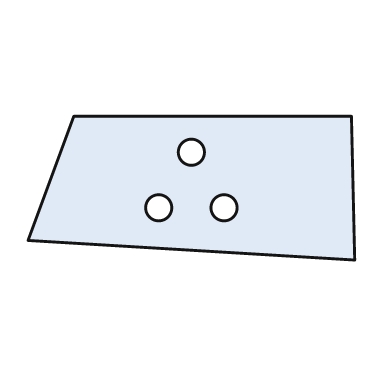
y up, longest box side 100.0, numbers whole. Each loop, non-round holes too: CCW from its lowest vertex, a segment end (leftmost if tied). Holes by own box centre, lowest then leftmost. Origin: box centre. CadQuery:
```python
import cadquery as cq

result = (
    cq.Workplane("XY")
    .moveTo(50.0, -22.0)
    .lineTo(49.0, 22.0)
    .lineTo(-36.0, 22.0)
    .lineTo(-50.0, -16.0)
    .close()
    .moveTo(-10.0, -6.0)
    .circle(4.0)
    .moveTo(10.0, -6.0)
    .circle(4.0)
    .moveTo(0.0, 11.0)
    .circle(4.0)
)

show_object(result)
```